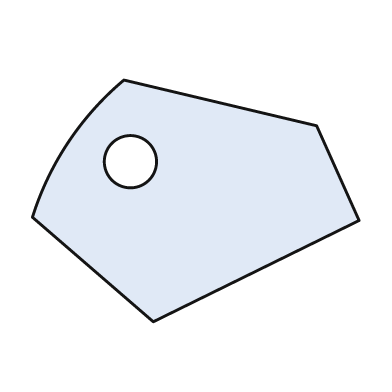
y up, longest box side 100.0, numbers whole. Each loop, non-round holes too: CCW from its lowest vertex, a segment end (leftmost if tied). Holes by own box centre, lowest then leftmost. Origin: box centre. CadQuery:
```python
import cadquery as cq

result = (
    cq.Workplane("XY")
    .moveTo(-13.0, -37.0)
    .lineTo(50.0, -6.0)
    .lineTo(37.0, 23.0)
    .lineTo(-22.0, 37.0)
    .threePointArc((-39.0, 18.0), (-50.0, -5.0))
    .close()
    .moveTo(-20.0, 12.0)
    .circle(8.0)
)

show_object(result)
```